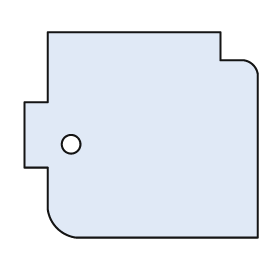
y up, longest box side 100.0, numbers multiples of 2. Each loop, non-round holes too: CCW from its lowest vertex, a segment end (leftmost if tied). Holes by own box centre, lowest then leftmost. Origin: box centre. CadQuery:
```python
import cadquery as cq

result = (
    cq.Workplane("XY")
    .moveTo(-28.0, -44.0)
    .lineTo(50.0, -44.0)
    .lineTo(50.0, 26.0)
    .threePointArc((48.0, 30.0), (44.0, 32.0))
    .lineTo(34.0, 32.0)
    .lineTo(34.0, 44.0)
    .lineTo(-40.0, 44.0)
    .lineTo(-40.0, 14.0)
    .lineTo(-50.0, 14.0)
    .lineTo(-50.0, -14.0)
    .lineTo(-40.0, -14.0)
    .lineTo(-40.0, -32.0)
    .threePointArc((-36.0, -40.0), (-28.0, -44.0))
    .close()
    .moveTo(-30.0, -4.0)
    .circle(4.0)
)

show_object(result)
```